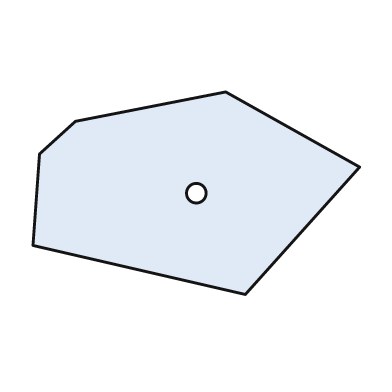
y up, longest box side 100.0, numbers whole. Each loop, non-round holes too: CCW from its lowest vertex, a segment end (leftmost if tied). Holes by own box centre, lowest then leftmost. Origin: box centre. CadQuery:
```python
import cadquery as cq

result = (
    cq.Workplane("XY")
    .moveTo(15.0, -31.0)
    .lineTo(50.0, 8.0)
    .lineTo(9.0, 31.0)
    .lineTo(-37.0, 22.0)
    .lineTo(-48.0, 12.0)
    .lineTo(-50.0, -16.0)
    .close()
    .moveTo(0.0, 0.0)
    .circle(3.0)
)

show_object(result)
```